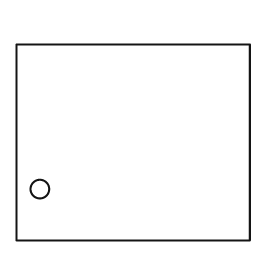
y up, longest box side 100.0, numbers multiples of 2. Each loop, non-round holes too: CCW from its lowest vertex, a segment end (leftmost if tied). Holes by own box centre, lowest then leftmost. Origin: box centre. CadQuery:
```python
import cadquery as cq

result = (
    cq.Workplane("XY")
    .moveTo(-50.0, -42.0)
    .lineTo(50.0, -42.0)
    .lineTo(50.0, 42.0)
    .lineTo(-50.0, 42.0)
    .close()
    .moveTo(-40.0, -20.0)
    .circle(4.0)
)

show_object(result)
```